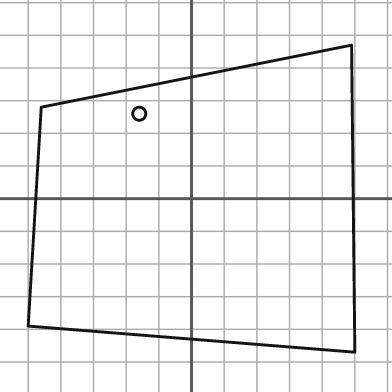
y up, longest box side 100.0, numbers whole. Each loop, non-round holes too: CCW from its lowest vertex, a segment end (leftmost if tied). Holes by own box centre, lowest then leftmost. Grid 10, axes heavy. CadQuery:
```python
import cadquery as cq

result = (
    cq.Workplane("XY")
    .moveTo(50.0, -47.0)
    .lineTo(49.0, 47.0)
    .lineTo(-46.0, 28.0)
    .lineTo(-50.0, -39.0)
    .close()
    .moveTo(-16.0, 26.0)
    .circle(2.0)
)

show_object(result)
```